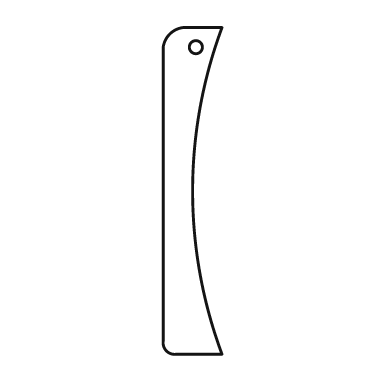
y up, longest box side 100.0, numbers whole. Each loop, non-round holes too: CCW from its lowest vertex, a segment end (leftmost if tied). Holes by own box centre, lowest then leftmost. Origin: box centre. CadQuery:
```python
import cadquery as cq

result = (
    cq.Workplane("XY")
    .moveTo(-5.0, -50.0)
    .lineTo(9.0, -50.0)
    .threePointArc((0.0, 0.0), (9.0, 50.0))
    .lineTo(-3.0, 50.0)
    .threePointArc((-7.0, 48.0), (-9.0, 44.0))
    .lineTo(-9.0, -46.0)
    .threePointArc((-8.0, -49.0), (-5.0, -50.0))
    .close()
    .moveTo(1.0, 44.0)
    .circle(2.0)
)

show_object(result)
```